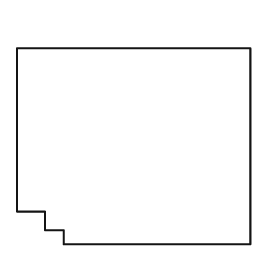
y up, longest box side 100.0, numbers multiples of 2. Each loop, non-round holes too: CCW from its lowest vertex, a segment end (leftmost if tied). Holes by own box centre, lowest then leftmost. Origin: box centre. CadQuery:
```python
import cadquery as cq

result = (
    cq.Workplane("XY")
    .moveTo(-30.0, -42.0)
    .lineTo(50.0, -42.0)
    .lineTo(50.0, 42.0)
    .lineTo(-50.0, 42.0)
    .lineTo(-50.0, -28.0)
    .lineTo(-38.0, -28.0)
    .lineTo(-38.0, -36.0)
    .lineTo(-30.0, -36.0)
    .close()
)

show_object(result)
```